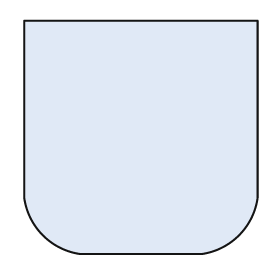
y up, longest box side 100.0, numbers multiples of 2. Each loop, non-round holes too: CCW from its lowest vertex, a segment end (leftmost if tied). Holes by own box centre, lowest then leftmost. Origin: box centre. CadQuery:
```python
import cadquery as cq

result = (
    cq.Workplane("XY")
    .moveTo(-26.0, -50.0)
    .lineTo(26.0, -50.0)
    .threePointArc((42.0, -42.0), (50.0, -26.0))
    .lineTo(50.0, 50.0)
    .lineTo(-50.0, 50.0)
    .lineTo(-50.0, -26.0)
    .threePointArc((-42.0, -42.0), (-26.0, -50.0))
    .close()
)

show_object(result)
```